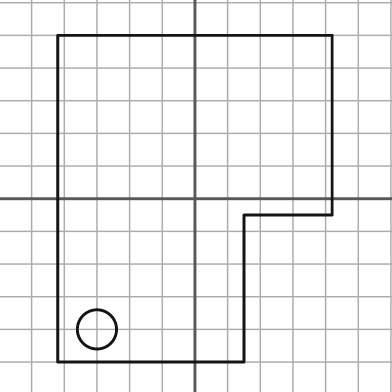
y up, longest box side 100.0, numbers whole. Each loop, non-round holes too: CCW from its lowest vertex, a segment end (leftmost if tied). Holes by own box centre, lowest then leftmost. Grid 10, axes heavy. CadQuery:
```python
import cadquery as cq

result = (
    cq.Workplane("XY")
    .moveTo(-42.0, -50.0)
    .lineTo(15.0, -50.0)
    .lineTo(15.0, -5.0)
    .lineTo(42.0, -5.0)
    .lineTo(42.0, 50.0)
    .lineTo(-42.0, 50.0)
    .close()
    .moveTo(-30.0, -40.0)
    .circle(6.0)
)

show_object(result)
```